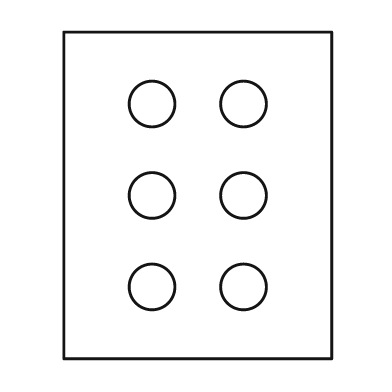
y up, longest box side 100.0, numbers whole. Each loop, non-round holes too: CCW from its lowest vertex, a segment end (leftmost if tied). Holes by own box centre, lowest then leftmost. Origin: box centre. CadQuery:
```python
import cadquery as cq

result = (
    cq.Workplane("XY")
    .moveTo(-41.0, -50.0)
    .lineTo(41.0, -50.0)
    .lineTo(41.0, 50.0)
    .lineTo(-41.0, 50.0)
    .close()
    .moveTo(-14.0, -28.0)
    .circle(7.0)
    .moveTo(14.0, -28.0)
    .circle(7.0)
    .moveTo(-14.0, 0.0)
    .circle(7.0)
    .moveTo(14.0, 0.0)
    .circle(7.0)
    .moveTo(-14.0, 28.0)
    .circle(7.0)
    .moveTo(14.0, 28.0)
    .circle(7.0)
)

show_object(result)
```